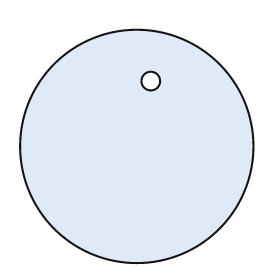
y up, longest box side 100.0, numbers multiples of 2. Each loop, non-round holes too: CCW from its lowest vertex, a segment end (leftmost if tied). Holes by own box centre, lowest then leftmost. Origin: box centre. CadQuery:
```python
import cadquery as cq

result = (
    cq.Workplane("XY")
    .moveTo(0.0, 0.0)
    .circle(50.0)
    .moveTo(6.0, 28.0)
    .circle(4.0)
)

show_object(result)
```